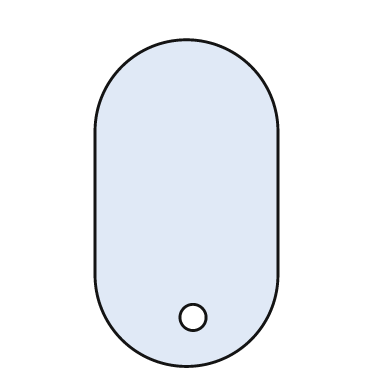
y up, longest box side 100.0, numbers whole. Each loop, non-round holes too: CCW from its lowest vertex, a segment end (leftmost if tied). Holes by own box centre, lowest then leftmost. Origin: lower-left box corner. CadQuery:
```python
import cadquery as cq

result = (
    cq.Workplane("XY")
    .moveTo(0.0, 28.0)
    .threePointArc((28.0, 0.0), (56.0, 28.0))
    .lineTo(56.0, 72.0)
    .threePointArc((28.0, 100.0), (0.0, 72.0))
    .close()
    .moveTo(30.0, 15.0)
    .circle(4.0)
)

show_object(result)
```